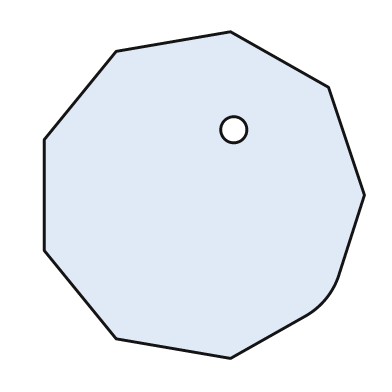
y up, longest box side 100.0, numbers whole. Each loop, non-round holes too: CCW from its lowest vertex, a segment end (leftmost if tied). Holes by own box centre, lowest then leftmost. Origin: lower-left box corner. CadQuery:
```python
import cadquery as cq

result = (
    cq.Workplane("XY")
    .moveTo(57.0, 0.0)
    .lineTo(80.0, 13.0)
    .threePointArc((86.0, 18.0), (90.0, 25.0))
    .lineTo(98.0, 50.0)
    .lineTo(87.0, 83.0)
    .lineTo(57.0, 100.0)
    .lineTo(22.0, 94.0)
    .lineTo(0.0, 67.0)
    .lineTo(0.0, 33.0)
    .lineTo(22.0, 6.0)
    .close()
    .moveTo(58.0, 70.0)
    .circle(4.0)
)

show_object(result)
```